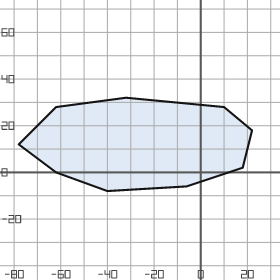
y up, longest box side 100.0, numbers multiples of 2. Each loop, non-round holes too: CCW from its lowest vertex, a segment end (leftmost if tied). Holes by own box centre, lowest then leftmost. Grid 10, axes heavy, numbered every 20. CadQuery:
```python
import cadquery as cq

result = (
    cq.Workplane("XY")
    .moveTo(-40.0, -8.0)
    .lineTo(-6.0, -6.0)
    .lineTo(18.0, 2.0)
    .lineTo(22.0, 18.0)
    .lineTo(10.0, 28.0)
    .lineTo(-32.0, 32.0)
    .lineTo(-62.0, 28.0)
    .lineTo(-78.0, 12.0)
    .lineTo(-62.0, 0.0)
    .close()
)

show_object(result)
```